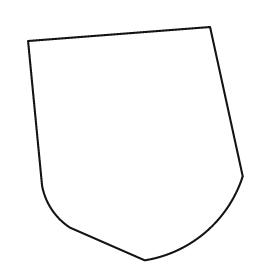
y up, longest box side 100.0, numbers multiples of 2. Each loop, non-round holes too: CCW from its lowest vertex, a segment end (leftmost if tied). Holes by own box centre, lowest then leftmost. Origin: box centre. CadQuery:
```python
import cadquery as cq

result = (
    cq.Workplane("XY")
    .moveTo(4.0, -50.0)
    .threePointArc((30.0, -38.0), (46.0, -14.0))
    .lineTo(32.0, 50.0)
    .lineTo(-46.0, 44.0)
    .lineTo(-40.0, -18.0)
    .threePointArc((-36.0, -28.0), (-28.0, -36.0))
    .close()
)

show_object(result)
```